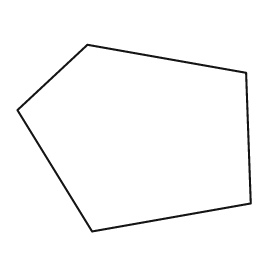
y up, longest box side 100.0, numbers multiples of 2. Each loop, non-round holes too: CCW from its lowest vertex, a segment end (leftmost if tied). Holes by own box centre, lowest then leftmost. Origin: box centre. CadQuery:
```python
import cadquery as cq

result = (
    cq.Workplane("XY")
    .moveTo(-18.0, -40.0)
    .lineTo(50.0, -28.0)
    .lineTo(48.0, 28.0)
    .lineTo(-20.0, 40.0)
    .lineTo(-50.0, 12.0)
    .close()
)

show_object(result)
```